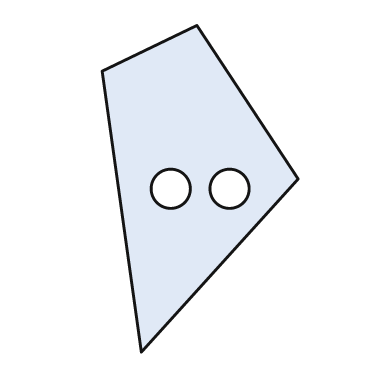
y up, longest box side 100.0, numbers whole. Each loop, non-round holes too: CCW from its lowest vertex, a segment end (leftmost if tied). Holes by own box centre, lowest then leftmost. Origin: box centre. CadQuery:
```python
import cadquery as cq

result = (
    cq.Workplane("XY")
    .moveTo(-18.0, -50.0)
    .lineTo(30.0, 3.0)
    .lineTo(-1.0, 50.0)
    .lineTo(-30.0, 36.0)
    .close()
    .moveTo(-9.0, 0.0)
    .circle(6.0)
    .moveTo(9.0, 0.0)
    .circle(6.0)
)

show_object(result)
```